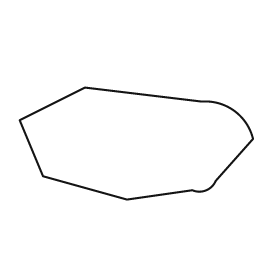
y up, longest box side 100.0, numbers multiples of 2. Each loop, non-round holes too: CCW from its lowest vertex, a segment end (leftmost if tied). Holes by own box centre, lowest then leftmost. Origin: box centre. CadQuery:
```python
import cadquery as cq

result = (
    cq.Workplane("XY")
    .moveTo(-4.0, -24.0)
    .lineTo(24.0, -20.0)
    .threePointArc((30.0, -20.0), (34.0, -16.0))
    .lineTo(50.0, 2.0)
    .threePointArc((42.0, 14.0), (28.0, 18.0))
    .lineTo(-22.0, 24.0)
    .lineTo(-50.0, 10.0)
    .lineTo(-40.0, -14.0)
    .close()
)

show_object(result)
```